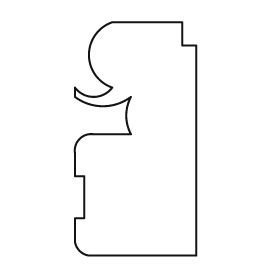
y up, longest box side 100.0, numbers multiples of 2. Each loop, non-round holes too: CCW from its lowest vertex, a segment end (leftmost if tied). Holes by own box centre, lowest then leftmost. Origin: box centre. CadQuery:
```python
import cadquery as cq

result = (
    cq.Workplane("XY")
    .moveTo(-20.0, -50.0)
    .lineTo(26.0, -50.0)
    .lineTo(26.0, 40.0)
    .lineTo(20.0, 40.0)
    .lineTo(20.0, 50.0)
    .lineTo(-10.0, 50.0)
    .threePointArc((-20.0, 36.0), (-10.0, 22.0))
    .threePointArc((-18.0, 18.0), (-26.0, 22.0))
    .lineTo(-26.0, 18.0)
    .threePointArc((-14.0, 14.0), (-2.0, 18.0))
    .threePointArc((-4.0, 10.0), (-2.0, 2.0))
    .lineTo(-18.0, 2.0)
    .threePointArc((-24.0, 0.0), (-26.0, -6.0))
    .lineTo(-26.0, -16.0)
    .lineTo(-22.0, -16.0)
    .lineTo(-22.0, -34.0)
    .lineTo(-26.0, -34.0)
    .lineTo(-26.0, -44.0)
    .threePointArc((-24.0, -48.0), (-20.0, -50.0))
    .close()
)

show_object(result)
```